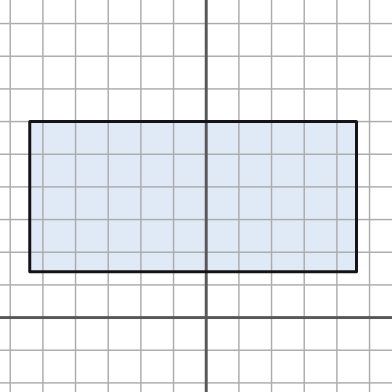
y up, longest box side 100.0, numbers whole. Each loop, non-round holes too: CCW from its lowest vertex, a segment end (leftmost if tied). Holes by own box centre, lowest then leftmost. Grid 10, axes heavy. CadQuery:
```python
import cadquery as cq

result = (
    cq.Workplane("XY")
    .moveTo(-54.0, 14.0)
    .lineTo(46.0, 14.0)
    .lineTo(46.0, 60.0)
    .lineTo(-54.0, 60.0)
    .close()
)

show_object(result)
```